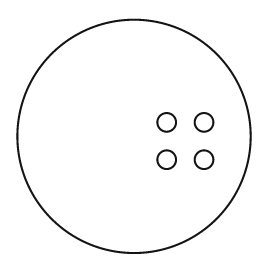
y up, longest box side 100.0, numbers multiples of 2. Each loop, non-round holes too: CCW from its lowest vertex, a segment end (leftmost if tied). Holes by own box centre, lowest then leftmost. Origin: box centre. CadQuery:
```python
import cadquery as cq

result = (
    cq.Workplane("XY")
    .moveTo(0.0, 0.0)
    .circle(50.0)
    .moveTo(14.0, -10.0)
    .circle(4.0)
    .moveTo(30.0, -10.0)
    .circle(4.0)
    .moveTo(14.0, 6.0)
    .circle(4.0)
    .moveTo(30.0, 6.0)
    .circle(4.0)
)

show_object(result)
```